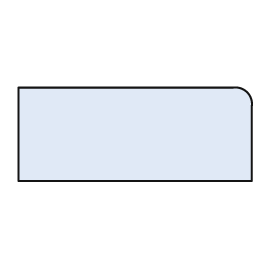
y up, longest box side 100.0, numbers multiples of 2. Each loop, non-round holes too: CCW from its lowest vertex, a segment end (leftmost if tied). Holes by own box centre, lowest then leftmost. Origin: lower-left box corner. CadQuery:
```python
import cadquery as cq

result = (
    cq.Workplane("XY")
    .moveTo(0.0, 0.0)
    .lineTo(100.0, 0.0)
    .lineTo(100.0, 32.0)
    .threePointArc((98.0, 38.0), (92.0, 40.0))
    .lineTo(0.0, 40.0)
    .close()
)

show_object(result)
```